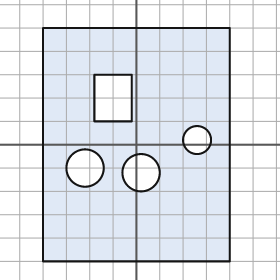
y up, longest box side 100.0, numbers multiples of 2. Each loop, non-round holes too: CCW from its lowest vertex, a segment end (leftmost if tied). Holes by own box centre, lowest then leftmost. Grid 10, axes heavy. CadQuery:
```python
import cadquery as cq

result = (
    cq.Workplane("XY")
    .moveTo(-40.0, -50.0)
    .lineTo(40.0, -50.0)
    .lineTo(40.0, 50.0)
    .lineTo(-40.0, 50.0)
    .close()
    .moveTo(2.0, -12.0)
    .circle(8.0)
    .moveTo(-22.0, -10.0)
    .circle(8.0)
    .moveTo(26.0, 2.0)
    .circle(6.0)
    .moveTo(-18.0, 10.0)
    .lineTo(-2.0, 10.0)
    .lineTo(-2.0, 30.0)
    .lineTo(-18.0, 30.0)
    .close()
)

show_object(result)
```